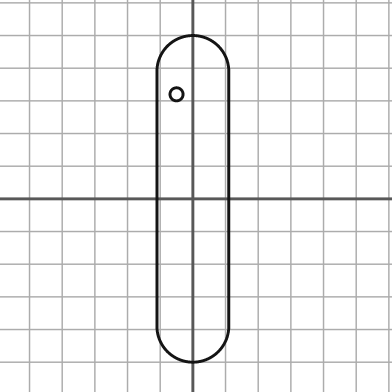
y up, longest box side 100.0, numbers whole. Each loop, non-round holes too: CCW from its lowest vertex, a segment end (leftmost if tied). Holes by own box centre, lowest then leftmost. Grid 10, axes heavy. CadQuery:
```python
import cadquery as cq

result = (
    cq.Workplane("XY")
    .moveTo(-11.0, -39.0)
    .threePointArc((0.0, -50.0), (11.0, -39.0))
    .lineTo(11.0, 39.0)
    .threePointArc((0.0, 50.0), (-11.0, 39.0))
    .close()
    .moveTo(-5.0, 32.0)
    .circle(2.0)
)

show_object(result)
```